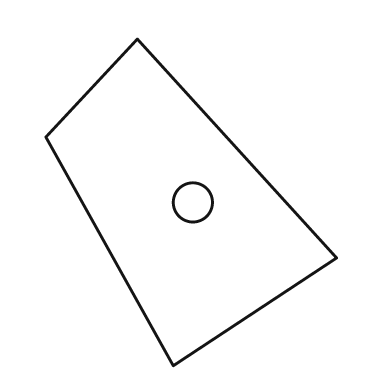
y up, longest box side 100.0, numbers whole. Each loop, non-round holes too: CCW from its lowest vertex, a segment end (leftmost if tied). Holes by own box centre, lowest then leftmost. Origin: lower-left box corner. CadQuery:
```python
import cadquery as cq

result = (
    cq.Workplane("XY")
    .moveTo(39.0, 0.0)
    .lineTo(89.0, 33.0)
    .lineTo(28.0, 100.0)
    .lineTo(0.0, 70.0)
    .close()
    .moveTo(45.0, 50.0)
    .circle(6.0)
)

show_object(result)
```